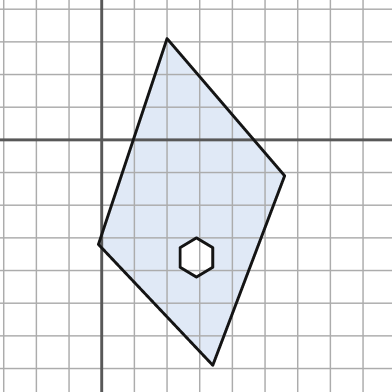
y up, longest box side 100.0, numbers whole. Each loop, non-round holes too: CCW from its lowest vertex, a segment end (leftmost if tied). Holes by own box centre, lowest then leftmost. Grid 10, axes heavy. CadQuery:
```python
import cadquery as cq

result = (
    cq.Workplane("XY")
    .moveTo(34.0, -69.0)
    .lineTo(56.0, -11.0)
    .lineTo(20.0, 31.0)
    .lineTo(-1.0, -32.0)
    .close()
    .moveTo(29.0, -42.0)
    .lineTo(34.0, -39.0)
    .lineTo(34.0, -33.0)
    .lineTo(29.0, -30.0)
    .lineTo(24.0, -33.0)
    .lineTo(24.0, -39.0)
    .close()
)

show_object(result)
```